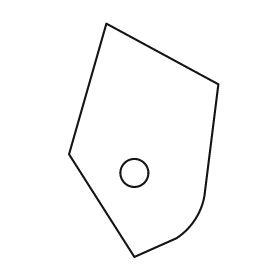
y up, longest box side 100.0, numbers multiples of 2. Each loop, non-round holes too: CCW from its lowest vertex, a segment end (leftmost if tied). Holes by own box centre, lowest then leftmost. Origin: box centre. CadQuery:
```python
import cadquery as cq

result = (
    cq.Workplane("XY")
    .moveTo(-4.0, -50.0)
    .lineTo(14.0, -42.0)
    .threePointArc((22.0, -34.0), (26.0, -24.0))
    .lineTo(32.0, 24.0)
    .lineTo(-16.0, 50.0)
    .lineTo(-32.0, -6.0)
    .close()
    .moveTo(-4.0, -14.0)
    .circle(6.0)
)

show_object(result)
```